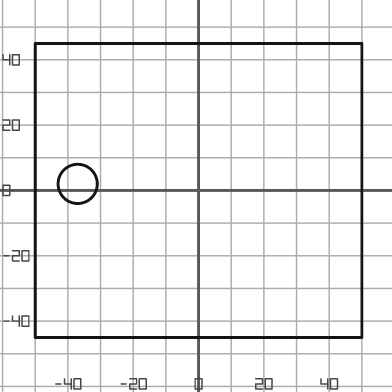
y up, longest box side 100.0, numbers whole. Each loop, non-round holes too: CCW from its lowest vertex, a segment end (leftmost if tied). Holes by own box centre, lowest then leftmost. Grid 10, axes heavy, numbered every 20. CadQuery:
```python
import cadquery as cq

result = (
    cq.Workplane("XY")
    .moveTo(-50.0, -45.0)
    .lineTo(50.0, -45.0)
    .lineTo(50.0, 45.0)
    .lineTo(-50.0, 45.0)
    .close()
    .moveTo(-37.0, 2.0)
    .circle(6.0)
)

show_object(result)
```